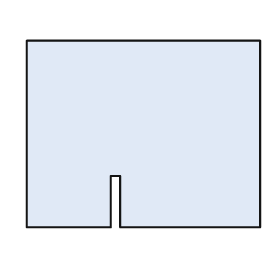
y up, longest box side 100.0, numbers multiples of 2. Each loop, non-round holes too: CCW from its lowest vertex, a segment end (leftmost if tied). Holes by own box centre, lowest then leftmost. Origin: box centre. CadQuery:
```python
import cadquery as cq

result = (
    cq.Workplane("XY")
    .moveTo(-50.0, -40.0)
    .lineTo(-14.0, -40.0)
    .lineTo(-14.0, -18.0)
    .lineTo(-10.0, -18.0)
    .lineTo(-10.0, -40.0)
    .lineTo(50.0, -40.0)
    .lineTo(50.0, 40.0)
    .lineTo(-50.0, 40.0)
    .close()
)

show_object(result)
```